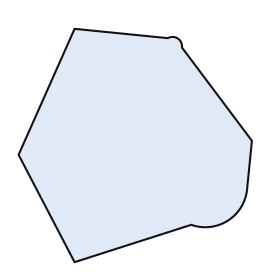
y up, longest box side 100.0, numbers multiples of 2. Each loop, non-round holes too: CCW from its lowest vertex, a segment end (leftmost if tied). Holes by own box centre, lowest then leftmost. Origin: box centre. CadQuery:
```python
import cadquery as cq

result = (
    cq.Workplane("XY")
    .moveTo(-26.0, -50.0)
    .lineTo(24.0, -34.0)
    .threePointArc((40.0, -32.0), (48.0, -18.0))
    .lineTo(50.0, 2.0)
    .lineTo(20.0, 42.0)
    .threePointArc((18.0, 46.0), (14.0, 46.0))
    .lineTo(-26.0, 50.0)
    .lineTo(-50.0, -4.0)
    .close()
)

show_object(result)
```